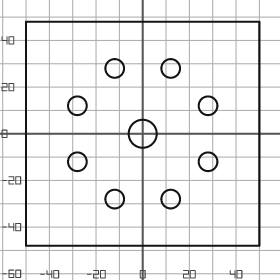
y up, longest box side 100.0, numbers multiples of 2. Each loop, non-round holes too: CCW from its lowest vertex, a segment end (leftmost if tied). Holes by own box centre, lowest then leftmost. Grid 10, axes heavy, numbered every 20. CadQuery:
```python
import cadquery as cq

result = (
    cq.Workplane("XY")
    .moveTo(-50.0, -48.0)
    .lineTo(50.0, -48.0)
    .lineTo(50.0, 48.0)
    .lineTo(-50.0, 48.0)
    .close()
    .moveTo(-12.0, -28.0)
    .circle(4.0)
    .moveTo(12.0, -28.0)
    .circle(4.0)
    .moveTo(-28.0, -12.0)
    .circle(4.0)
    .moveTo(28.0, -12.0)
    .circle(4.0)
    .moveTo(0.0, 0.0)
    .circle(6.0)
    .moveTo(-28.0, 12.0)
    .circle(4.0)
    .moveTo(28.0, 12.0)
    .circle(4.0)
    .moveTo(-12.0, 28.0)
    .circle(4.0)
    .moveTo(12.0, 28.0)
    .circle(4.0)
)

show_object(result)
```